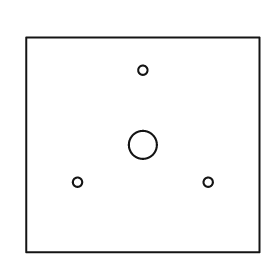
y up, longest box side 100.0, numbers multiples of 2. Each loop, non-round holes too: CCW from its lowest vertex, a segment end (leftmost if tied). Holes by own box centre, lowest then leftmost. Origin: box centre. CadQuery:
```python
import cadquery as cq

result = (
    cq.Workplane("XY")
    .moveTo(-50.0, -46.0)
    .lineTo(50.0, -46.0)
    .lineTo(50.0, 46.0)
    .lineTo(-50.0, 46.0)
    .close()
    .moveTo(-28.0, -16.0)
    .circle(2.0)
    .moveTo(28.0, -16.0)
    .circle(2.0)
    .moveTo(0.0, 0.0)
    .circle(6.0)
    .moveTo(0.0, 32.0)
    .circle(2.0)
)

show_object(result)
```